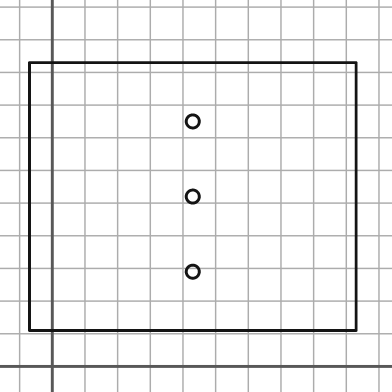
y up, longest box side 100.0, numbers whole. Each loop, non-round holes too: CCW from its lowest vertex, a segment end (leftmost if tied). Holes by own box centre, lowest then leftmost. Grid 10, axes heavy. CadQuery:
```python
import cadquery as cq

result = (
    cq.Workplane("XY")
    .moveTo(-7.0, 11.0)
    .lineTo(93.0, 11.0)
    .lineTo(93.0, 93.0)
    .lineTo(-7.0, 93.0)
    .close()
    .moveTo(43.0, 29.0)
    .circle(2.0)
    .moveTo(43.0, 52.0)
    .circle(2.0)
    .moveTo(43.0, 75.0)
    .circle(2.0)
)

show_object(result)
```